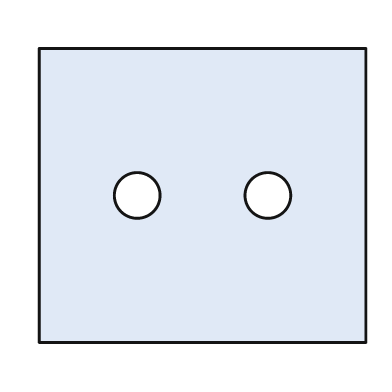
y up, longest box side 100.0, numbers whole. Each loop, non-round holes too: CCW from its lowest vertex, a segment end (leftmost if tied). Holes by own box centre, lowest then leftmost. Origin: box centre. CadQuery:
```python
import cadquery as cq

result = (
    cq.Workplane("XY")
    .moveTo(-50.0, -45.0)
    .lineTo(50.0, -45.0)
    .lineTo(50.0, 45.0)
    .lineTo(-50.0, 45.0)
    .close()
    .moveTo(-20.0, 0.0)
    .circle(7.0)
    .moveTo(20.0, 0.0)
    .circle(7.0)
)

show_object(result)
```